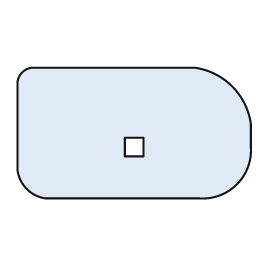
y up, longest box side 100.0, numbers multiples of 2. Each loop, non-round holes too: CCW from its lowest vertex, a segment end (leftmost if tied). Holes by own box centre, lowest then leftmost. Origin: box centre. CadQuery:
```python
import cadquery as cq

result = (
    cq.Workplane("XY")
    .moveTo(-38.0, -28.0)
    .lineTo(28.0, -28.0)
    .threePointArc((44.0, -22.0), (50.0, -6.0))
    .lineTo(50.0, 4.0)
    .threePointArc((42.0, 20.0), (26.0, 28.0))
    .lineTo(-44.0, 28.0)
    .threePointArc((-48.0, 26.0), (-50.0, 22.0))
    .lineTo(-50.0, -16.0)
    .threePointArc((-46.0, -24.0), (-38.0, -28.0))
    .close()
    .moveTo(-4.0, -10.0)
    .lineTo(4.0, -10.0)
    .lineTo(4.0, -2.0)
    .lineTo(-4.0, -2.0)
    .close()
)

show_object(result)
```